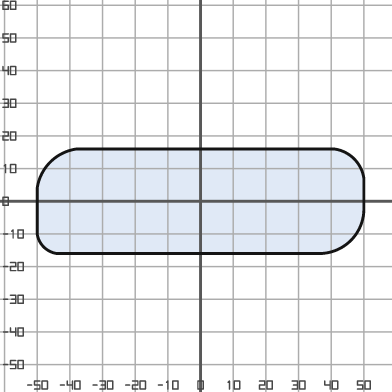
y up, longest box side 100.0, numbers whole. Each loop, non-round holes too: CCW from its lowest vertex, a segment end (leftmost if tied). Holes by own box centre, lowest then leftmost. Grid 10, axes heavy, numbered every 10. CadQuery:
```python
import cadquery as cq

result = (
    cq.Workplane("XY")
    .moveTo(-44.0, -16.0)
    .lineTo(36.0, -16.0)
    .threePointArc((46.0, -12.0), (50.0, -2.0))
    .lineTo(50.0, 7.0)
    .threePointArc((47.0, 13.0), (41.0, 16.0))
    .lineTo(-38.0, 16.0)
    .threePointArc((-46.0, 12.0), (-50.0, 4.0))
    .lineTo(-50.0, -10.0)
    .threePointArc((-48.0, -14.0), (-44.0, -16.0))
    .close()
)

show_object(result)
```